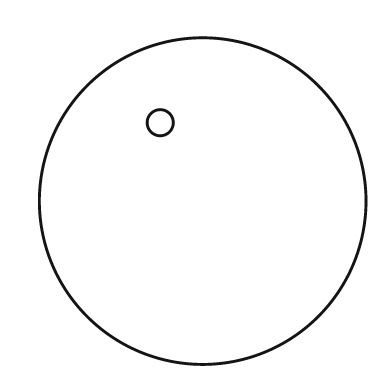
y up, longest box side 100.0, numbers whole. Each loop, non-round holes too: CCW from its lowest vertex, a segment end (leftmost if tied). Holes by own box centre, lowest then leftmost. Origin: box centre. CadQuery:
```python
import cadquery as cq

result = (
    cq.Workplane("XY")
    .moveTo(0.0, 0.0)
    .circle(50.0)
    .moveTo(-13.0, 24.0)
    .circle(4.0)
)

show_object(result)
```